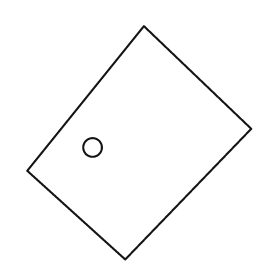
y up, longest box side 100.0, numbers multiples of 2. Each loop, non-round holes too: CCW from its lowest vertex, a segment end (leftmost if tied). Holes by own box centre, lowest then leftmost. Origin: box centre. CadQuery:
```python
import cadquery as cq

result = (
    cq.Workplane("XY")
    .moveTo(-6.0, -50.0)
    .lineTo(48.0, 6.0)
    .lineTo(2.0, 50.0)
    .lineTo(-48.0, -12.0)
    .close()
    .moveTo(-20.0, -2.0)
    .circle(4.0)
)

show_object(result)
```